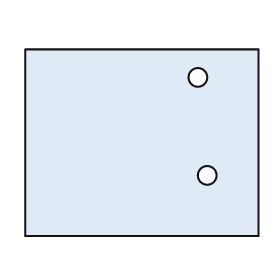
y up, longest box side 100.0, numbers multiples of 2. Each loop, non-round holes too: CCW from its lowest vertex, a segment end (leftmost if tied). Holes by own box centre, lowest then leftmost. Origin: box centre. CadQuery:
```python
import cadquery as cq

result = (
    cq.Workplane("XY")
    .moveTo(-50.0, -40.0)
    .lineTo(50.0, -40.0)
    .lineTo(50.0, 40.0)
    .lineTo(-50.0, 40.0)
    .close()
    .moveTo(28.0, -14.0)
    .circle(4.0)
    .moveTo(24.0, 28.0)
    .circle(4.0)
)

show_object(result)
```